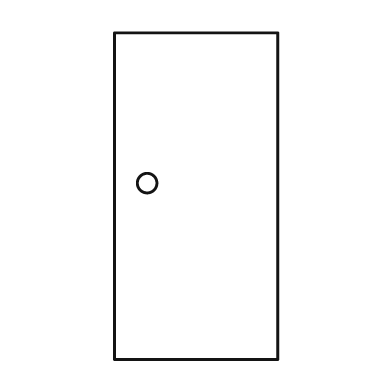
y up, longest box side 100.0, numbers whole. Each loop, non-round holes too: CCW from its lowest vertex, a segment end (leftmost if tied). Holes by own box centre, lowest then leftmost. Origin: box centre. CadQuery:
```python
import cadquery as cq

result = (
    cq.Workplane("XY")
    .moveTo(-25.0, -50.0)
    .lineTo(25.0, -50.0)
    .lineTo(25.0, 50.0)
    .lineTo(-25.0, 50.0)
    .close()
    .moveTo(-15.0, 4.0)
    .circle(3.0)
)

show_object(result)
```